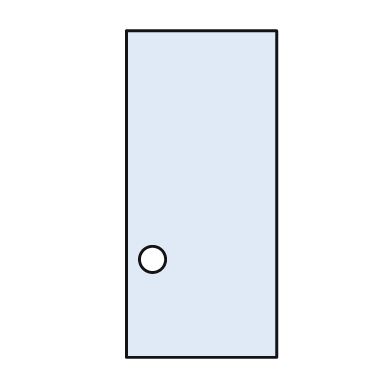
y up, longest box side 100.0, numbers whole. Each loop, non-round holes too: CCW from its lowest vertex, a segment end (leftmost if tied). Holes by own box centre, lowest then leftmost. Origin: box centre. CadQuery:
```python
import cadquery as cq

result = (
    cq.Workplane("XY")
    .moveTo(-23.0, -50.0)
    .lineTo(23.0, -50.0)
    .lineTo(23.0, 50.0)
    .lineTo(-23.0, 50.0)
    .close()
    .moveTo(-15.0, -20.0)
    .circle(4.0)
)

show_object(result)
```